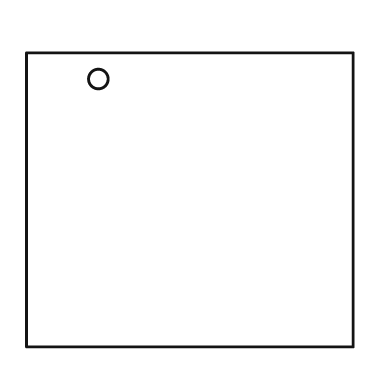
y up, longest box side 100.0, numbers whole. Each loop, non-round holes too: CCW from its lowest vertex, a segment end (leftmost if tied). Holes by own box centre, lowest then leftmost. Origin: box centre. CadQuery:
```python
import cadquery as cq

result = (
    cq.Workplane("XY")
    .moveTo(-50.0, -45.0)
    .lineTo(50.0, -45.0)
    .lineTo(50.0, 45.0)
    .lineTo(-50.0, 45.0)
    .close()
    .moveTo(-28.0, 37.0)
    .circle(3.0)
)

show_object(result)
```